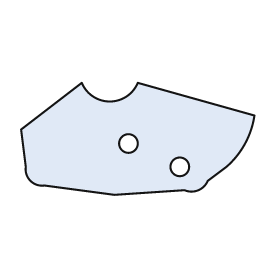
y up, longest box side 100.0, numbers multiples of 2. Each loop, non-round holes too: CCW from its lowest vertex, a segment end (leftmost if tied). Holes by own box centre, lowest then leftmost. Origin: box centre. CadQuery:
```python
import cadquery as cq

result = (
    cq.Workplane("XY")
    .moveTo(-10.0, -24.0)
    .lineTo(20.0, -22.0)
    .threePointArc((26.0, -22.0), (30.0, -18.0))
    .lineTo(38.0, -12.0)
    .threePointArc((46.0, -2.0), (50.0, 10.0))
    .lineTo(0.0, 24.0)
    .threePointArc((-12.0, 16.0), (-24.0, 24.0))
    .lineTo(-50.0, 4.0)
    .lineTo(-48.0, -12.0)
    .threePointArc((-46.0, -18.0), (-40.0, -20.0))
    .close()
    .moveTo(18.0, -12.0)
    .circle(4.0)
    .moveTo(-4.0, -2.0)
    .circle(4.0)
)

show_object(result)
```